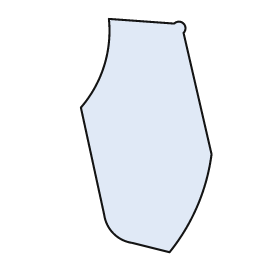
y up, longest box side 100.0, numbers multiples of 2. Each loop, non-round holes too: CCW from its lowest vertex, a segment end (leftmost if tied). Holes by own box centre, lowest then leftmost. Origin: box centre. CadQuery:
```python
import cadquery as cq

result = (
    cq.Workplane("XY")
    .moveTo(10.0, -50.0)
    .threePointArc((22.0, -30.0), (28.0, -8.0))
    .lineTo(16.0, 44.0)
    .threePointArc((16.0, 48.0), (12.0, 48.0))
    .lineTo(-16.0, 50.0)
    .threePointArc((-18.0, 30.0), (-28.0, 12.0))
    .lineTo(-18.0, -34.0)
    .threePointArc((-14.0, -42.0), (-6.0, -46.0))
    .close()
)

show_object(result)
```